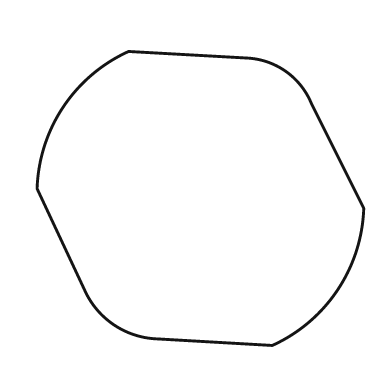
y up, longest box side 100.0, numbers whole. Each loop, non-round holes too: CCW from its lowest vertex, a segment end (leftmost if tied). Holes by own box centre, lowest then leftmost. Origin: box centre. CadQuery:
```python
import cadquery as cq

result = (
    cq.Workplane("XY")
    .moveTo(22.0, -45.0)
    .threePointArc((42.0, -28.0), (50.0, -3.0))
    .lineTo(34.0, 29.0)
    .threePointArc((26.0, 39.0), (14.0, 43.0))
    .lineTo(-22.0, 45.0)
    .threePointArc((-42.0, 28.0), (-50.0, 3.0))
    .lineTo(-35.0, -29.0)
    .threePointArc((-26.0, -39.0), (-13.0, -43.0))
    .close()
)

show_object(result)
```